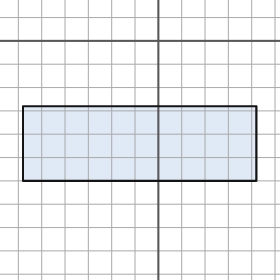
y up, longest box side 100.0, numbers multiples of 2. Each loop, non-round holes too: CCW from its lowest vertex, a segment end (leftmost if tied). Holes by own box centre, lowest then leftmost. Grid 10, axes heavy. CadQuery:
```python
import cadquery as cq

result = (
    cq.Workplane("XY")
    .moveTo(-58.0, -60.0)
    .lineTo(42.0, -60.0)
    .lineTo(42.0, -28.0)
    .lineTo(-58.0, -28.0)
    .close()
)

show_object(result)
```